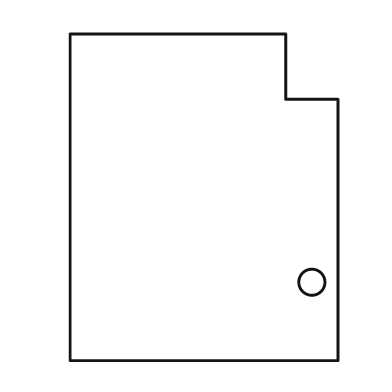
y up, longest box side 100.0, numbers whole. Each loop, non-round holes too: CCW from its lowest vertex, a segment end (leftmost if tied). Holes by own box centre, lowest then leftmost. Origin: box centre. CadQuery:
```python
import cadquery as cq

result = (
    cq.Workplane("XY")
    .moveTo(-41.0, -50.0)
    .lineTo(41.0, -50.0)
    .lineTo(41.0, 30.0)
    .lineTo(25.0, 30.0)
    .lineTo(25.0, 50.0)
    .lineTo(-41.0, 50.0)
    .close()
    .moveTo(33.0, -26.0)
    .circle(4.0)
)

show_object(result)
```